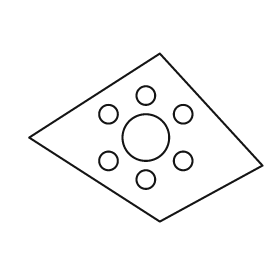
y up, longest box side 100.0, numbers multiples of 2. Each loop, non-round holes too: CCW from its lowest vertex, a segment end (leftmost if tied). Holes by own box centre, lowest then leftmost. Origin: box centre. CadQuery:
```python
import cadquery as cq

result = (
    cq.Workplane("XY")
    .moveTo(6.0, -36.0)
    .lineTo(50.0, -12.0)
    .lineTo(6.0, 36.0)
    .lineTo(-50.0, 0.0)
    .close()
    .moveTo(0.0, -18.0)
    .circle(4.0)
    .moveTo(-16.0, -10.0)
    .circle(4.0)
    .moveTo(16.0, -10.0)
    .circle(4.0)
    .moveTo(0.0, 0.0)
    .circle(10.0)
    .moveTo(-16.0, 10.0)
    .circle(4.0)
    .moveTo(16.0, 10.0)
    .circle(4.0)
    .moveTo(0.0, 18.0)
    .circle(4.0)
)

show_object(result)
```